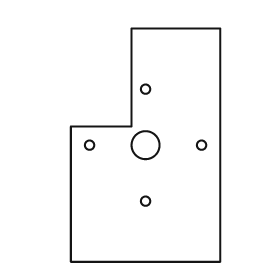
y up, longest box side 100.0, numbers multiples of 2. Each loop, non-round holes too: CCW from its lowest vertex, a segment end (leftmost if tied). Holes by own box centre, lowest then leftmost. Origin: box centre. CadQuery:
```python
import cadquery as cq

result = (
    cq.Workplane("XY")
    .moveTo(-32.0, -50.0)
    .lineTo(32.0, -50.0)
    .lineTo(32.0, 50.0)
    .lineTo(-6.0, 50.0)
    .lineTo(-6.0, 8.0)
    .lineTo(-32.0, 8.0)
    .close()
    .moveTo(0.0, -24.0)
    .circle(2.0)
    .moveTo(-24.0, 0.0)
    .circle(2.0)
    .moveTo(0.0, 0.0)
    .circle(6.0)
    .moveTo(24.0, 0.0)
    .circle(2.0)
    .moveTo(0.0, 24.0)
    .circle(2.0)
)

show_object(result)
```